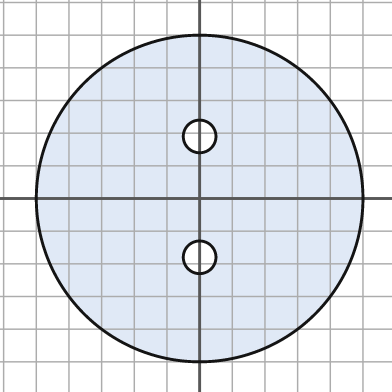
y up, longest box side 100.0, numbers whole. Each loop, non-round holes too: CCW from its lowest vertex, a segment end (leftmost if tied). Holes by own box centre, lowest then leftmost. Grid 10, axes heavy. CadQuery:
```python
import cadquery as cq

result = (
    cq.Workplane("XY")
    .moveTo(0.0, 0.0)
    .circle(50.0)
    .moveTo(0.0, -18.0)
    .circle(5.0)
    .moveTo(0.0, 19.0)
    .circle(5.0)
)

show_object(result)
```